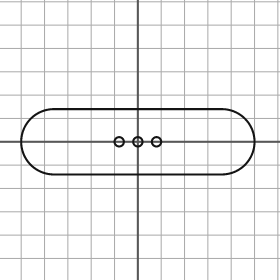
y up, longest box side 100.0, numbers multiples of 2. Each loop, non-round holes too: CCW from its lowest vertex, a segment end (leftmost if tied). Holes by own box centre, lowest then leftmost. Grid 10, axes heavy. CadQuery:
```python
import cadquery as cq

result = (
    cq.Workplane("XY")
    .moveTo(-36.0, -14.0)
    .lineTo(36.0, -14.0)
    .threePointArc((50.0, 0.0), (36.0, 14.0))
    .lineTo(-36.0, 14.0)
    .threePointArc((-50.0, 0.0), (-36.0, -14.0))
    .close()
    .moveTo(-8.0, 0.0)
    .circle(2.0)
    .moveTo(0.0, 0.0)
    .circle(2.0)
    .moveTo(8.0, 0.0)
    .circle(2.0)
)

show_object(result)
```